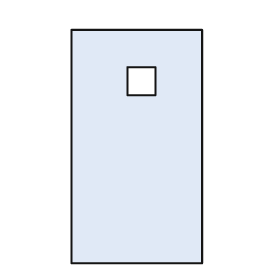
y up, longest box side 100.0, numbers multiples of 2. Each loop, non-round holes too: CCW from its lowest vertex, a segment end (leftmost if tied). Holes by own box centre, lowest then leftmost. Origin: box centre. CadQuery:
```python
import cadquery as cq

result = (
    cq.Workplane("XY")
    .moveTo(-28.0, -50.0)
    .lineTo(28.0, -50.0)
    .lineTo(28.0, 50.0)
    .lineTo(-28.0, 50.0)
    .close()
    .moveTo(-4.0, 22.0)
    .lineTo(8.0, 22.0)
    .lineTo(8.0, 34.0)
    .lineTo(-4.0, 34.0)
    .close()
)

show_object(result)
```